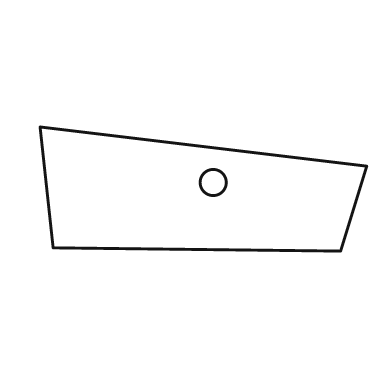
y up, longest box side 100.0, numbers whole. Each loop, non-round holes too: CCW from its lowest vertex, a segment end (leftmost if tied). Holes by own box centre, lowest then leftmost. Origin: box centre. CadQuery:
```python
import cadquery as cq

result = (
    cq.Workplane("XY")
    .moveTo(42.0, -19.0)
    .lineTo(50.0, 7.0)
    .lineTo(-50.0, 19.0)
    .lineTo(-46.0, -18.0)
    .close()
    .moveTo(3.0, 2.0)
    .circle(4.0)
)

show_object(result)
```